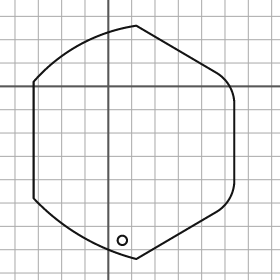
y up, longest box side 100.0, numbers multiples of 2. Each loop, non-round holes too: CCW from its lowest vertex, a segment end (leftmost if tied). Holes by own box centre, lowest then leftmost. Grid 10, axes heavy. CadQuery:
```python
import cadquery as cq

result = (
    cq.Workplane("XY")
    .moveTo(12.0, -74.0)
    .lineTo(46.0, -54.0)
    .threePointArc((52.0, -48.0), (54.0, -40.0))
    .lineTo(54.0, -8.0)
    .threePointArc((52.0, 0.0), (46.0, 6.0))
    .lineTo(12.0, 26.0)
    .threePointArc((-12.0, 18.0), (-32.0, 2.0))
    .lineTo(-32.0, -48.0)
    .threePointArc((-12.0, -64.0), (12.0, -74.0))
    .close()
    .moveTo(6.0, -66.0)
    .circle(2.0)
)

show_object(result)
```